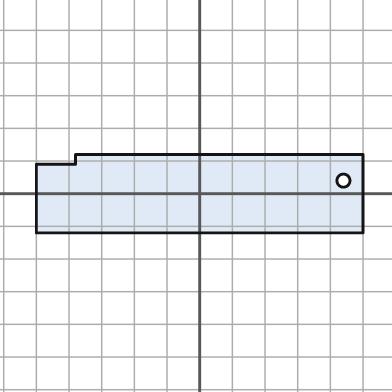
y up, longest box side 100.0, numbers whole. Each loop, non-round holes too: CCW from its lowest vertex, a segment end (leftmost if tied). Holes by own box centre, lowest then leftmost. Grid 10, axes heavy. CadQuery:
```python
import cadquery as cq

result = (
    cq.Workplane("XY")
    .moveTo(-50.0, -12.0)
    .lineTo(50.0, -12.0)
    .lineTo(50.0, 12.0)
    .lineTo(-38.0, 12.0)
    .lineTo(-38.0, 9.0)
    .lineTo(-50.0, 9.0)
    .close()
    .moveTo(44.0, 4.0)
    .circle(2.0)
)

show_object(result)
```